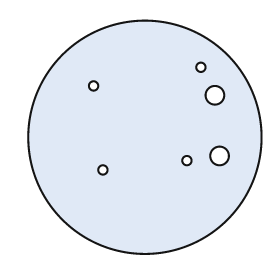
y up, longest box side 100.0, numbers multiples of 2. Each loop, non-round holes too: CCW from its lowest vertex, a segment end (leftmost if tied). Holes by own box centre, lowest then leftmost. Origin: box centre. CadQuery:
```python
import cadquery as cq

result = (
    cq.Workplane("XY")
    .moveTo(0.0, 0.0)
    .circle(50.0)
    .moveTo(-18.0, -14.0)
    .circle(2.0)
    .moveTo(18.0, -10.0)
    .circle(2.0)
    .moveTo(32.0, -8.0)
    .circle(4.0)
    .moveTo(30.0, 18.0)
    .circle(4.0)
    .moveTo(-22.0, 22.0)
    .circle(2.0)
    .moveTo(24.0, 30.0)
    .circle(2.0)
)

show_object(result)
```